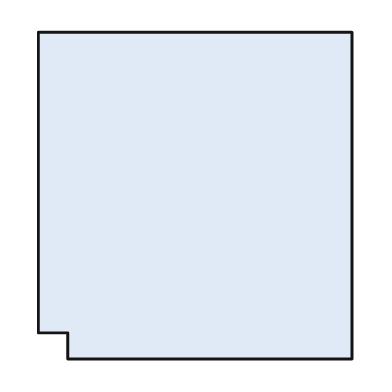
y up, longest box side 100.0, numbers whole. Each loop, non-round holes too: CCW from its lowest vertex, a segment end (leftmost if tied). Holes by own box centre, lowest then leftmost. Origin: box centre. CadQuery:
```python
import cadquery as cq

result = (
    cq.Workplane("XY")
    .moveTo(-39.0, -50.0)
    .lineTo(48.0, -50.0)
    .lineTo(48.0, 50.0)
    .lineTo(-48.0, 50.0)
    .lineTo(-48.0, -42.0)
    .lineTo(-39.0, -42.0)
    .close()
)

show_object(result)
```